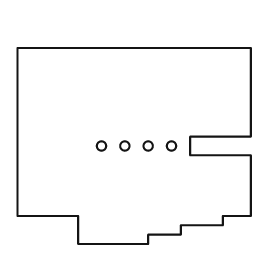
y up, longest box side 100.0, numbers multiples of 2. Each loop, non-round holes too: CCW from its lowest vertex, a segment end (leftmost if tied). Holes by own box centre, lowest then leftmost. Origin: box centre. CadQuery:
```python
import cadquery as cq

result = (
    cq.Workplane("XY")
    .moveTo(-24.0, -42.0)
    .lineTo(6.0, -42.0)
    .lineTo(6.0, -38.0)
    .lineTo(20.0, -38.0)
    .lineTo(20.0, -34.0)
    .lineTo(38.0, -34.0)
    .lineTo(38.0, -30.0)
    .lineTo(50.0, -30.0)
    .lineTo(50.0, -4.0)
    .lineTo(24.0, -4.0)
    .lineTo(24.0, 4.0)
    .lineTo(50.0, 4.0)
    .lineTo(50.0, 42.0)
    .lineTo(-50.0, 42.0)
    .lineTo(-50.0, -30.0)
    .lineTo(-24.0, -30.0)
    .close()
    .moveTo(-14.0, 0.0)
    .circle(2.0)
    .moveTo(-4.0, 0.0)
    .circle(2.0)
    .moveTo(6.0, 0.0)
    .circle(2.0)
    .moveTo(16.0, 0.0)
    .circle(2.0)
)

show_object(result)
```